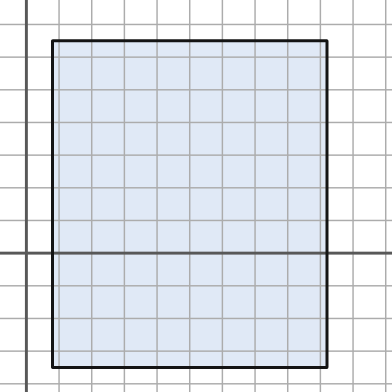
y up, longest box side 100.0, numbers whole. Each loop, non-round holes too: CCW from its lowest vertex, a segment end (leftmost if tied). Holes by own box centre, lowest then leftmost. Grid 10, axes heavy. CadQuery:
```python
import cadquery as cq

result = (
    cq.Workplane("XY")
    .moveTo(8.0, -35.0)
    .lineTo(92.0, -35.0)
    .lineTo(92.0, 65.0)
    .lineTo(8.0, 65.0)
    .close()
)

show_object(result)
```